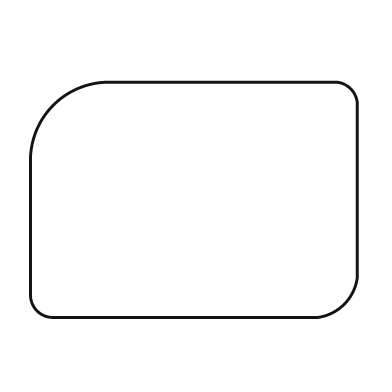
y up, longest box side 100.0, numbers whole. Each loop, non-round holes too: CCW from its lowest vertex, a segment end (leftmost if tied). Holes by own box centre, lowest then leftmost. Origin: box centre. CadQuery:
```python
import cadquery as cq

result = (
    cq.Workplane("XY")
    .moveTo(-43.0, -36.0)
    .lineTo(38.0, -36.0)
    .threePointArc((46.0, -32.0), (50.0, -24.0))
    .lineTo(50.0, 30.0)
    .threePointArc((48.0, 34.0), (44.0, 36.0))
    .lineTo(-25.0, 36.0)
    .threePointArc((-43.0, 29.0), (-50.0, 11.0))
    .lineTo(-50.0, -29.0)
    .threePointArc((-48.0, -34.0), (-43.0, -36.0))
    .close()
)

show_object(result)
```